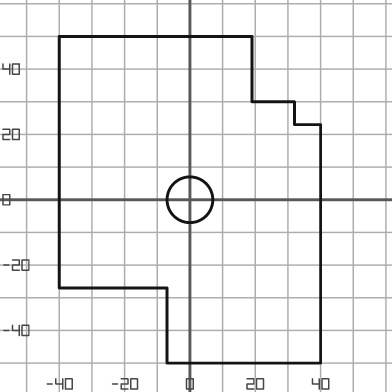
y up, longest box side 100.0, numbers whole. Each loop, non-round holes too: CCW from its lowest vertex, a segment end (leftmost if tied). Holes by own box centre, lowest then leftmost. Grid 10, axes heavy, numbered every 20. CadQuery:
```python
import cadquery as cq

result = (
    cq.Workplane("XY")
    .moveTo(-7.0, -50.0)
    .lineTo(40.0, -50.0)
    .lineTo(40.0, 23.0)
    .lineTo(32.0, 23.0)
    .lineTo(32.0, 30.0)
    .lineTo(19.0, 30.0)
    .lineTo(19.0, 50.0)
    .lineTo(-40.0, 50.0)
    .lineTo(-40.0, -27.0)
    .lineTo(-7.0, -27.0)
    .close()
    .moveTo(0.0, 0.0)
    .circle(7.0)
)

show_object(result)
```